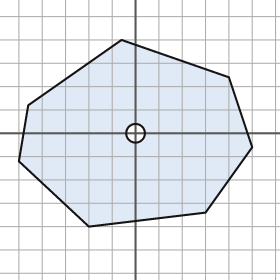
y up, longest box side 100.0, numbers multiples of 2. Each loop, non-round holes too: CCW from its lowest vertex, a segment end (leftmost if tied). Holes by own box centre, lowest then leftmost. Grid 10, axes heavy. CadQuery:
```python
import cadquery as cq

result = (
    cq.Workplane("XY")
    .moveTo(-20.0, -40.0)
    .lineTo(30.0, -34.0)
    .lineTo(50.0, -6.0)
    .lineTo(40.0, 24.0)
    .lineTo(-6.0, 40.0)
    .lineTo(-46.0, 12.0)
    .lineTo(-50.0, -12.0)
    .close()
    .moveTo(0.0, 0.0)
    .circle(4.0)
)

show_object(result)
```